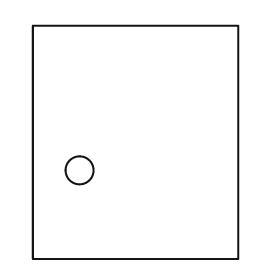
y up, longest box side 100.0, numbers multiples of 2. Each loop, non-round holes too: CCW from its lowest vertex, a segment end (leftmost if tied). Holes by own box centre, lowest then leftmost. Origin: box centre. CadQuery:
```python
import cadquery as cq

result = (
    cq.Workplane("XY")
    .moveTo(-44.0, -50.0)
    .lineTo(44.0, -50.0)
    .lineTo(44.0, 50.0)
    .lineTo(-44.0, 50.0)
    .close()
    .moveTo(-24.0, -12.0)
    .circle(6.0)
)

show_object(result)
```